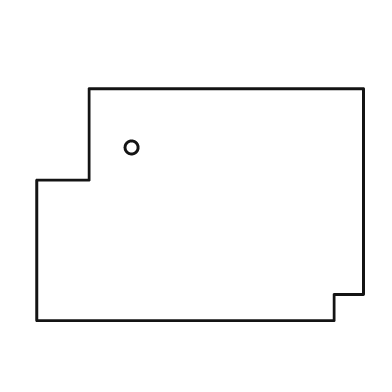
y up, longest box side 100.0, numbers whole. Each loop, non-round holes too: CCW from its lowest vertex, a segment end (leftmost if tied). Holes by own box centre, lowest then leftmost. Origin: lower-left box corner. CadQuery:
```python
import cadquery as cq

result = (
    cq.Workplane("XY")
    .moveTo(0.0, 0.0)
    .lineTo(91.0, 0.0)
    .lineTo(91.0, 8.0)
    .lineTo(100.0, 8.0)
    .lineTo(100.0, 71.0)
    .lineTo(16.0, 71.0)
    .lineTo(16.0, 43.0)
    .lineTo(0.0, 43.0)
    .close()
    .moveTo(29.0, 53.0)
    .circle(2.0)
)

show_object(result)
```